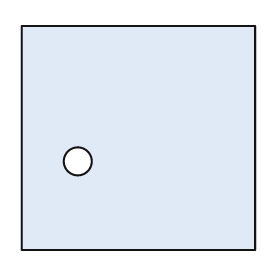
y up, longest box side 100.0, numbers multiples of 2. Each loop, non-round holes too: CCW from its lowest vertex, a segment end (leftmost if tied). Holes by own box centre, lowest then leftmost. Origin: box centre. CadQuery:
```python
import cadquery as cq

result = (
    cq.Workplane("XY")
    .moveTo(-50.0, -48.0)
    .lineTo(50.0, -48.0)
    .lineTo(50.0, 48.0)
    .lineTo(-50.0, 48.0)
    .close()
    .moveTo(-26.0, -10.0)
    .circle(6.0)
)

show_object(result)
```